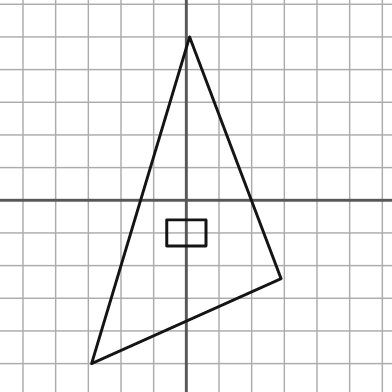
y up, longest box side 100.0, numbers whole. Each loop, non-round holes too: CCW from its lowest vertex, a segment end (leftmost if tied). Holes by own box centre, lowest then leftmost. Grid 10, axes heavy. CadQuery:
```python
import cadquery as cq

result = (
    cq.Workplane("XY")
    .moveTo(-29.0, -50.0)
    .lineTo(29.0, -24.0)
    .lineTo(1.0, 50.0)
    .close()
    .moveTo(-6.0, -14.0)
    .lineTo(6.0, -14.0)
    .lineTo(6.0, -6.0)
    .lineTo(-6.0, -6.0)
    .close()
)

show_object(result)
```